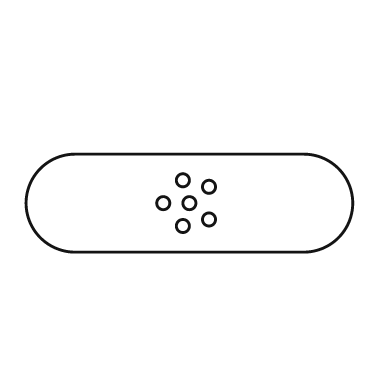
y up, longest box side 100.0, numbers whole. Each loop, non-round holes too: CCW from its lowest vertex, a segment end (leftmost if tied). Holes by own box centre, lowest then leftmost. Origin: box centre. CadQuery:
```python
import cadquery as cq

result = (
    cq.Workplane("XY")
    .moveTo(-35.0, -15.0)
    .lineTo(35.0, -15.0)
    .threePointArc((50.0, 0.0), (35.0, 15.0))
    .lineTo(-35.0, 15.0)
    .threePointArc((-50.0, 0.0), (-35.0, -15.0))
    .close()
    .moveTo(-2.0, -7.0)
    .circle(2.0)
    .moveTo(6.0, -5.0)
    .circle(2.0)
    .moveTo(-8.0, 0.0)
    .circle(2.0)
    .moveTo(0.0, 0.0)
    .circle(2.0)
    .moveTo(6.0, 5.0)
    .circle(2.0)
    .moveTo(-2.0, 7.0)
    .circle(2.0)
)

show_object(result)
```